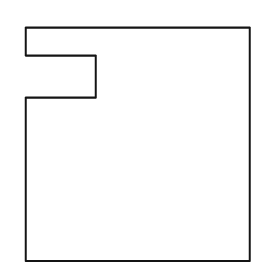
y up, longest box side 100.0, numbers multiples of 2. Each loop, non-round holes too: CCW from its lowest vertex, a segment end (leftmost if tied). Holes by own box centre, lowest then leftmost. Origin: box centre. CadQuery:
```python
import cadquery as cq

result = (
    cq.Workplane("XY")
    .moveTo(-48.0, -50.0)
    .lineTo(48.0, -50.0)
    .lineTo(48.0, 50.0)
    .lineTo(-48.0, 50.0)
    .lineTo(-48.0, 38.0)
    .lineTo(-18.0, 38.0)
    .lineTo(-18.0, 20.0)
    .lineTo(-48.0, 20.0)
    .close()
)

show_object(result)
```